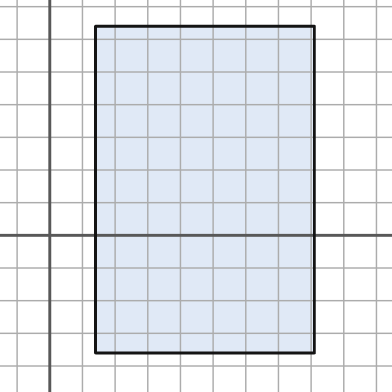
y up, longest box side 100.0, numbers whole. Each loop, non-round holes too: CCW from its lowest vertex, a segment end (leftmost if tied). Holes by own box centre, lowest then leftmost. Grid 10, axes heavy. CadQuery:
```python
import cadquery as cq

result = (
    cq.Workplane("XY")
    .moveTo(14.0, -36.0)
    .lineTo(81.0, -36.0)
    .lineTo(81.0, 64.0)
    .lineTo(14.0, 64.0)
    .close()
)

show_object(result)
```